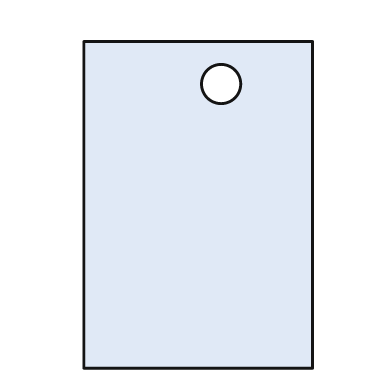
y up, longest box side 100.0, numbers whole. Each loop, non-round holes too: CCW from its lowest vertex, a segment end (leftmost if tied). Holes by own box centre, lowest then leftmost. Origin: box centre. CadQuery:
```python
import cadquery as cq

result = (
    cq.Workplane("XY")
    .moveTo(-35.0, -50.0)
    .lineTo(35.0, -50.0)
    .lineTo(35.0, 50.0)
    .lineTo(-35.0, 50.0)
    .close()
    .moveTo(7.0, 37.0)
    .circle(6.0)
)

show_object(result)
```